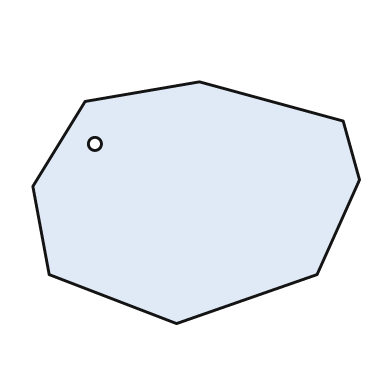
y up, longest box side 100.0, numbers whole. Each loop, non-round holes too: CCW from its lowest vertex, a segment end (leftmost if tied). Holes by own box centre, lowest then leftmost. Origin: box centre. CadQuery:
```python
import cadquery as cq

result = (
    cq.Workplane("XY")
    .moveTo(-6.0, -37.0)
    .lineTo(37.0, -22.0)
    .lineTo(50.0, 7.0)
    .lineTo(45.0, 25.0)
    .lineTo(1.0, 37.0)
    .lineTo(-34.0, 31.0)
    .lineTo(-50.0, 5.0)
    .lineTo(-45.0, -22.0)
    .close()
    .moveTo(-31.0, 18.0)
    .circle(2.0)
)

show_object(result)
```